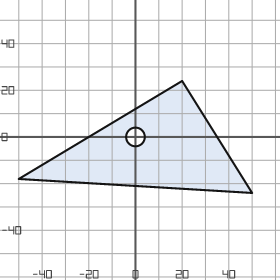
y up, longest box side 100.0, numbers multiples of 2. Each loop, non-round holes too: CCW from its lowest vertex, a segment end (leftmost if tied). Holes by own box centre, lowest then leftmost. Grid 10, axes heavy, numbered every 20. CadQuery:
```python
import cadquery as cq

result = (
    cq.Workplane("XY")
    .moveTo(50.0, -24.0)
    .lineTo(20.0, 24.0)
    .lineTo(-50.0, -18.0)
    .close()
    .moveTo(0.0, 0.0)
    .circle(4.0)
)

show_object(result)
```